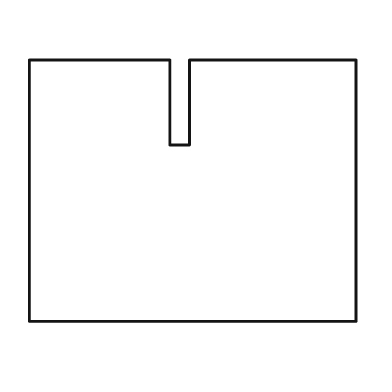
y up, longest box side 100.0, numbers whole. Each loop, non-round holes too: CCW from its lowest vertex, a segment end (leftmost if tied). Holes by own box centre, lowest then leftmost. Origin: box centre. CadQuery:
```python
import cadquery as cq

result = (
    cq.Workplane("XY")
    .moveTo(-50.0, -40.0)
    .lineTo(50.0, -40.0)
    .lineTo(50.0, 40.0)
    .lineTo(-1.0, 40.0)
    .lineTo(-1.0, 14.0)
    .lineTo(-7.0, 14.0)
    .lineTo(-7.0, 40.0)
    .lineTo(-50.0, 40.0)
    .close()
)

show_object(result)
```